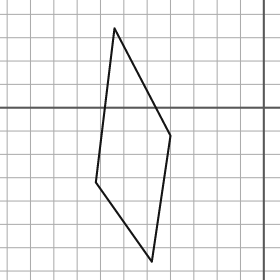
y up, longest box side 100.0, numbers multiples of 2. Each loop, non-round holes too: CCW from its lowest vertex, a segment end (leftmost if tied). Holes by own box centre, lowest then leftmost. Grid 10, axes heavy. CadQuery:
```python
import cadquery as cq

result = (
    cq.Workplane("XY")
    .moveTo(-48.0, -66.0)
    .lineTo(-40.0, -12.0)
    .lineTo(-64.0, 34.0)
    .lineTo(-72.0, -32.0)
    .close()
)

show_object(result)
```